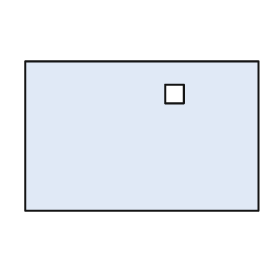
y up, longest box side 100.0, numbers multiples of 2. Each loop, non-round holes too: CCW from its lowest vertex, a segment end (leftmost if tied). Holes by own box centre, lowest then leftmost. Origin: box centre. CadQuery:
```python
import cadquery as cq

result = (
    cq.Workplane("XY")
    .moveTo(-50.0, -32.0)
    .lineTo(50.0, -32.0)
    .lineTo(50.0, 32.0)
    .lineTo(-50.0, 32.0)
    .close()
    .moveTo(10.0, 14.0)
    .lineTo(18.0, 14.0)
    .lineTo(18.0, 22.0)
    .lineTo(10.0, 22.0)
    .close()
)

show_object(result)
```